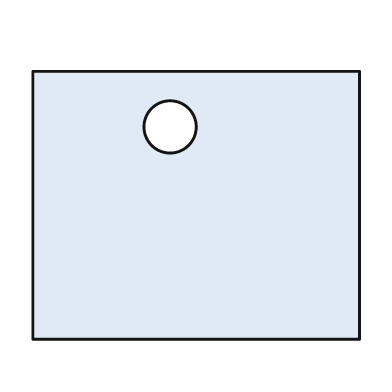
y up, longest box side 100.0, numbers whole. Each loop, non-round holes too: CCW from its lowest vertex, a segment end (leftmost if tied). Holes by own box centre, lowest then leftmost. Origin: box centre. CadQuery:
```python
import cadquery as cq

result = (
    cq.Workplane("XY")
    .moveTo(-50.0, -41.0)
    .lineTo(50.0, -41.0)
    .lineTo(50.0, 41.0)
    .lineTo(-50.0, 41.0)
    .close()
    .moveTo(-8.0, 24.0)
    .circle(8.0)
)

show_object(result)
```